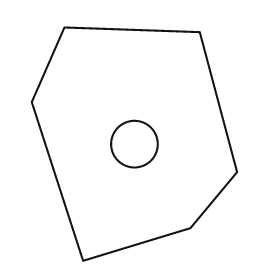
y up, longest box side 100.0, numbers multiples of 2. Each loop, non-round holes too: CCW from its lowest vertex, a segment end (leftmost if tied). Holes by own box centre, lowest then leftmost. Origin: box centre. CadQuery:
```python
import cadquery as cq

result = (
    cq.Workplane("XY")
    .moveTo(-22.0, -50.0)
    .lineTo(24.0, -36.0)
    .lineTo(44.0, -12.0)
    .lineTo(28.0, 48.0)
    .lineTo(-30.0, 50.0)
    .lineTo(-44.0, 18.0)
    .close()
    .moveTo(0.0, 0.0)
    .circle(10.0)
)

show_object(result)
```